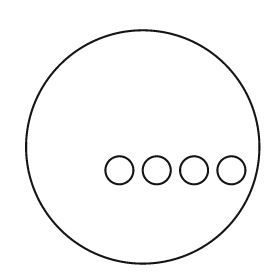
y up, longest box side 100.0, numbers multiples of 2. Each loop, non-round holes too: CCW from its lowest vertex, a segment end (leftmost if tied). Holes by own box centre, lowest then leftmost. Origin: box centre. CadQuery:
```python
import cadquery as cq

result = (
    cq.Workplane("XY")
    .moveTo(0.0, 0.0)
    .circle(50.0)
    .moveTo(-10.0, -10.0)
    .circle(6.0)
    .moveTo(6.0, -10.0)
    .circle(6.0)
    .moveTo(22.0, -10.0)
    .circle(6.0)
    .moveTo(38.0, -10.0)
    .circle(6.0)
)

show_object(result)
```